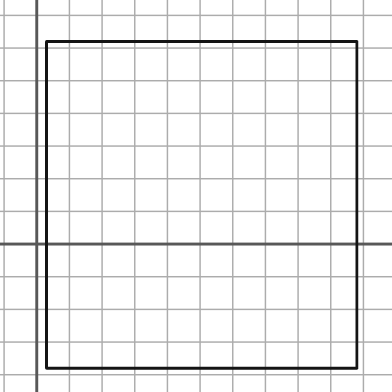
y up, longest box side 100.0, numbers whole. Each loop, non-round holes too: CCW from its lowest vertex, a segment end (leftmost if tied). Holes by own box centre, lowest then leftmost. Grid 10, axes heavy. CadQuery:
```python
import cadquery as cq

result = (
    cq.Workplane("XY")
    .moveTo(3.0, -38.0)
    .lineTo(98.0, -38.0)
    .lineTo(98.0, 62.0)
    .lineTo(3.0, 62.0)
    .close()
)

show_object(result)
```